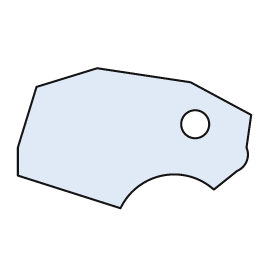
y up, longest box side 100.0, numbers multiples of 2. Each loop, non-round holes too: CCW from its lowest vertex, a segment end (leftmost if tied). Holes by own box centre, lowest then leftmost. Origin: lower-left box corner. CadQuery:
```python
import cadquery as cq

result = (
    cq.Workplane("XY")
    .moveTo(44.0, 0.0)
    .threePointArc((62.0, 14.0), (84.0, 8.0))
    .lineTo(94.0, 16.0)
    .threePointArc((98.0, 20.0), (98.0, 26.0))
    .lineTo(100.0, 40.0)
    .lineTo(74.0, 54.0)
    .lineTo(34.0, 60.0)
    .lineTo(8.0, 52.0)
    .lineTo(0.0, 26.0)
    .lineTo(0.0, 14.0)
    .close()
    .moveTo(76.0, 36.0)
    .circle(6.0)
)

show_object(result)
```